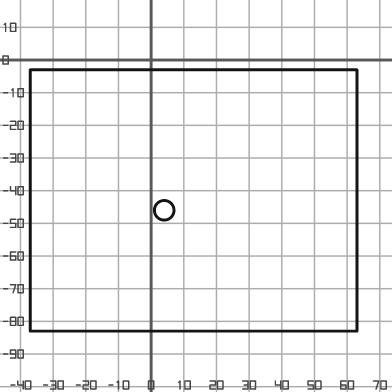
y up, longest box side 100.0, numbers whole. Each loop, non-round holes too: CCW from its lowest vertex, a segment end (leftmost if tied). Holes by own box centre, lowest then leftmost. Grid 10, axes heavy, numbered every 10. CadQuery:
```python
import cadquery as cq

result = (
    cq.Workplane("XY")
    .moveTo(-37.0, -83.0)
    .lineTo(63.0, -83.0)
    .lineTo(63.0, -3.0)
    .lineTo(-37.0, -3.0)
    .close()
    .moveTo(4.0, -46.0)
    .circle(3.0)
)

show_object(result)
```